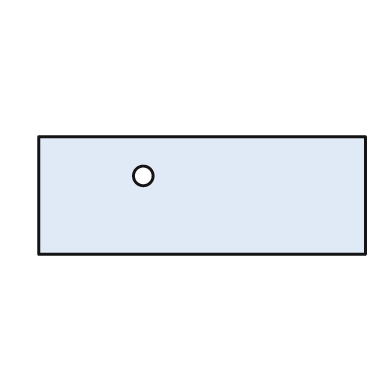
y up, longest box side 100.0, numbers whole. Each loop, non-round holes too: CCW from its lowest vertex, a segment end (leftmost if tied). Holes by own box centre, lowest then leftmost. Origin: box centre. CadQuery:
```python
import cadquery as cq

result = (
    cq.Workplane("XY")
    .moveTo(-50.0, -18.0)
    .lineTo(50.0, -18.0)
    .lineTo(50.0, 18.0)
    .lineTo(-50.0, 18.0)
    .close()
    .moveTo(-18.0, 6.0)
    .circle(3.0)
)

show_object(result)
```